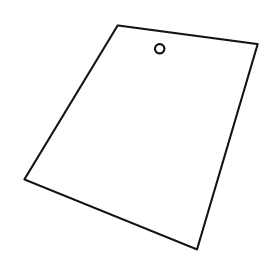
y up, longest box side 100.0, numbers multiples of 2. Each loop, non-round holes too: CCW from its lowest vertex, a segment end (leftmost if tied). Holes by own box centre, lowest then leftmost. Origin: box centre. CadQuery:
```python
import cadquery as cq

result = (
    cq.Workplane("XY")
    .moveTo(24.0, -48.0)
    .lineTo(50.0, 40.0)
    .lineTo(-10.0, 48.0)
    .lineTo(-50.0, -18.0)
    .close()
    .moveTo(8.0, 38.0)
    .circle(2.0)
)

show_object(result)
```